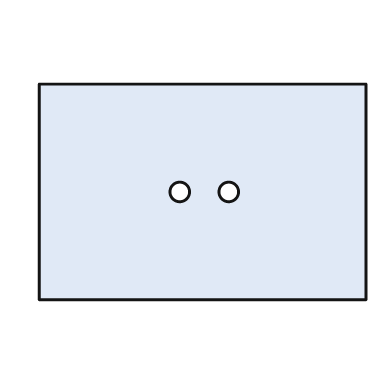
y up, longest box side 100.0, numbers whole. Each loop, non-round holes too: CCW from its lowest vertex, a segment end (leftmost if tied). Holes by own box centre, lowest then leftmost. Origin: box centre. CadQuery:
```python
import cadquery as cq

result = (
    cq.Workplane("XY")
    .moveTo(-50.0, -33.0)
    .lineTo(50.0, -33.0)
    .lineTo(50.0, 33.0)
    .lineTo(-50.0, 33.0)
    .close()
    .moveTo(-7.0, 0.0)
    .circle(3.0)
    .moveTo(8.0, 0.0)
    .circle(3.0)
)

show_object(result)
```